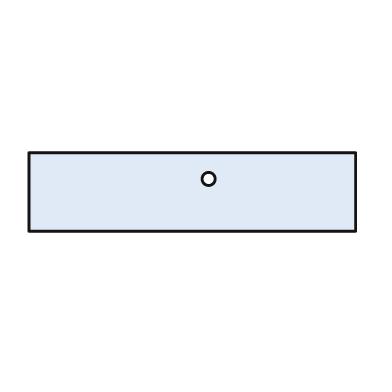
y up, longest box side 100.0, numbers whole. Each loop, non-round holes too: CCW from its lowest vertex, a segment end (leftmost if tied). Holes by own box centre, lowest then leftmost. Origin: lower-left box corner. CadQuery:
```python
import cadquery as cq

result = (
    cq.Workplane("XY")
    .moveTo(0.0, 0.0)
    .lineTo(100.0, 0.0)
    .lineTo(100.0, 24.0)
    .lineTo(0.0, 24.0)
    .close()
    .moveTo(55.0, 16.0)
    .circle(2.0)
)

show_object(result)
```